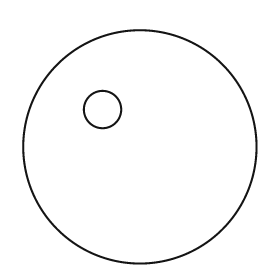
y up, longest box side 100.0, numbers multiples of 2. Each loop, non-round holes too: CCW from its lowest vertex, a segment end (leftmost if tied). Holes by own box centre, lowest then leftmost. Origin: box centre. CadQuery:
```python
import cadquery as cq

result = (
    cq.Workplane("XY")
    .moveTo(0.0, 0.0)
    .circle(50.0)
    .moveTo(-16.0, 16.0)
    .circle(8.0)
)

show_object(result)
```